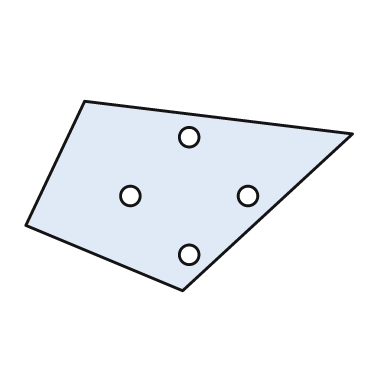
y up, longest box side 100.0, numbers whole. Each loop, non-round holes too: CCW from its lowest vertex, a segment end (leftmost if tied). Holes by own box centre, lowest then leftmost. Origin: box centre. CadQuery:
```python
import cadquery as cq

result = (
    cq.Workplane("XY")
    .moveTo(-2.0, -29.0)
    .lineTo(50.0, 19.0)
    .lineTo(-32.0, 29.0)
    .lineTo(-50.0, -9.0)
    .close()
    .moveTo(0.0, -18.0)
    .circle(3.0)
    .moveTo(-18.0, 0.0)
    .circle(3.0)
    .moveTo(18.0, 0.0)
    .circle(3.0)
    .moveTo(0.0, 18.0)
    .circle(3.0)
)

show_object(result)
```